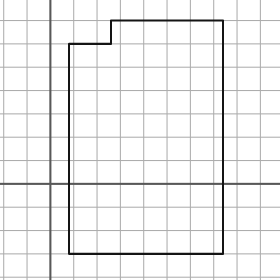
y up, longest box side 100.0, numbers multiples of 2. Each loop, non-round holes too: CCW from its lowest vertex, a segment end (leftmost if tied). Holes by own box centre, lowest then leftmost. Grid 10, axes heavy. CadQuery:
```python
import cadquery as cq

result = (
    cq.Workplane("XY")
    .moveTo(8.0, -30.0)
    .lineTo(74.0, -30.0)
    .lineTo(74.0, 70.0)
    .lineTo(26.0, 70.0)
    .lineTo(26.0, 60.0)
    .lineTo(8.0, 60.0)
    .close()
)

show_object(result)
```